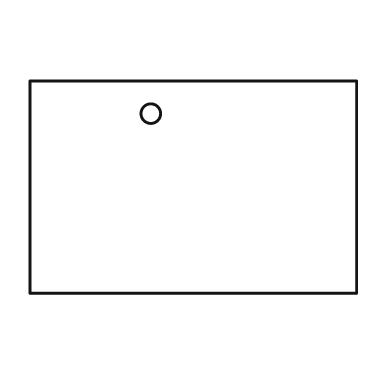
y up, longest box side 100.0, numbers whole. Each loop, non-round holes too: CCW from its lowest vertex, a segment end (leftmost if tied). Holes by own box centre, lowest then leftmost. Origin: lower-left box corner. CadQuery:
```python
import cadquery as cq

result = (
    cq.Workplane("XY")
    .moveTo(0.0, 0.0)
    .lineTo(100.0, 0.0)
    .lineTo(100.0, 65.0)
    .lineTo(0.0, 65.0)
    .close()
    .moveTo(37.0, 55.0)
    .circle(3.0)
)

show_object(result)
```